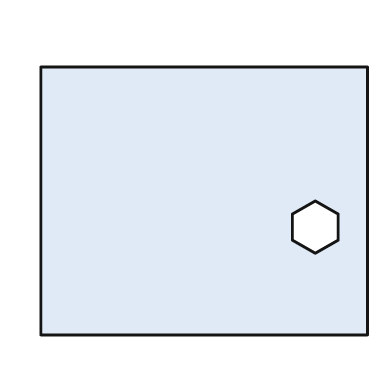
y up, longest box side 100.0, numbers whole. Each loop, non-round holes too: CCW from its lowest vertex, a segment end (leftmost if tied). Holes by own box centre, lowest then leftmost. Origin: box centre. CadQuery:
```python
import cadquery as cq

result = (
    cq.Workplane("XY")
    .moveTo(-50.0, -41.0)
    .lineTo(50.0, -41.0)
    .lineTo(50.0, 41.0)
    .lineTo(-50.0, 41.0)
    .close()
    .moveTo(34.0, -16.0)
    .lineTo(41.0, -12.0)
    .lineTo(41.0, -4.0)
    .lineTo(34.0, 0.0)
    .lineTo(27.0, -4.0)
    .lineTo(27.0, -12.0)
    .close()
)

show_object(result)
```